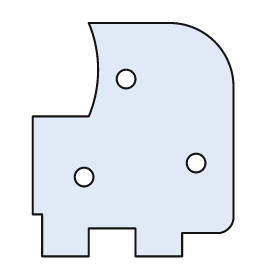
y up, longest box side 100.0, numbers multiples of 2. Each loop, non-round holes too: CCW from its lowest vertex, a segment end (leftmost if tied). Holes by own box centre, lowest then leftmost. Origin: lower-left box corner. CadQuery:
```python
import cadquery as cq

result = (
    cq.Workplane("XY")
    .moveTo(4.0, 0.0)
    .lineTo(24.0, 0.0)
    .lineTo(24.0, 12.0)
    .lineTo(44.0, 12.0)
    .lineTo(44.0, 0.0)
    .lineTo(64.0, 0.0)
    .lineTo(64.0, 10.0)
    .lineTo(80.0, 10.0)
    .threePointArc((84.0, 12.0), (86.0, 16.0))
    .lineTo(86.0, 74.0)
    .threePointArc((78.0, 92.0), (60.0, 100.0))
    .lineTo(24.0, 100.0)
    .threePointArc((28.0, 80.0), (24.0, 60.0))
    .lineTo(0.0, 60.0)
    .lineTo(0.0, 18.0)
    .lineTo(4.0, 18.0)
    .close()
    .moveTo(22.0, 34.0)
    .circle(4.0)
    .moveTo(70.0, 40.0)
    .circle(4.0)
    .moveTo(40.0, 76.0)
    .circle(4.0)
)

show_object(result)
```